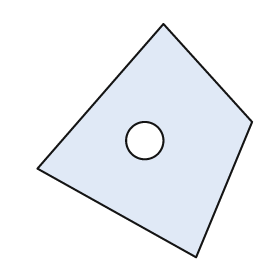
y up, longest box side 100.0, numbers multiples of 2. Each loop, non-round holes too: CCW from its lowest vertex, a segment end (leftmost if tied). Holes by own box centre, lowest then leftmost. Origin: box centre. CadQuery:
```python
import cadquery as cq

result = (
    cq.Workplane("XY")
    .moveTo(22.0, -50.0)
    .lineTo(46.0, 8.0)
    .lineTo(8.0, 50.0)
    .lineTo(-46.0, -12.0)
    .close()
    .moveTo(0.0, 0.0)
    .circle(8.0)
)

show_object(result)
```